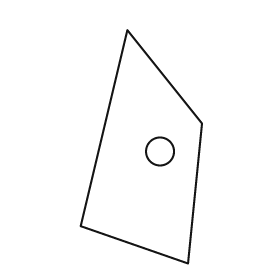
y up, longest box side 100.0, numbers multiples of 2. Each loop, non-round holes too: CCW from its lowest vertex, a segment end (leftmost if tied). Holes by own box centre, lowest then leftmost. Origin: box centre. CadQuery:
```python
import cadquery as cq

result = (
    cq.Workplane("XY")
    .moveTo(20.0, -50.0)
    .lineTo(26.0, 10.0)
    .lineTo(-6.0, 50.0)
    .lineTo(-26.0, -34.0)
    .close()
    .moveTo(8.0, -2.0)
    .circle(6.0)
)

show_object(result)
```